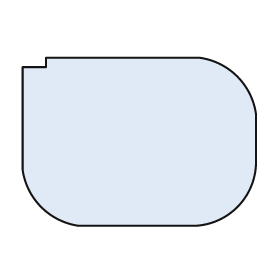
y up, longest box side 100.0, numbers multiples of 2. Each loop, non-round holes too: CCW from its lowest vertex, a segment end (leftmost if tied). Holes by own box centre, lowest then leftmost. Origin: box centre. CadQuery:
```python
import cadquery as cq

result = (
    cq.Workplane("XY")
    .moveTo(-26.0, -36.0)
    .lineTo(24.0, -36.0)
    .threePointArc((42.0, -28.0), (50.0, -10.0))
    .lineTo(50.0, 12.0)
    .threePointArc((42.0, 28.0), (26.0, 36.0))
    .lineTo(-40.0, 36.0)
    .lineTo(-40.0, 32.0)
    .lineTo(-50.0, 32.0)
    .lineTo(-50.0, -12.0)
    .threePointArc((-42.0, -28.0), (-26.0, -36.0))
    .close()
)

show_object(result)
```